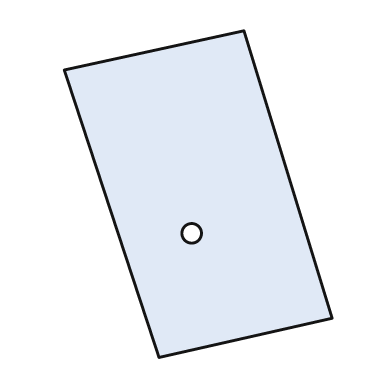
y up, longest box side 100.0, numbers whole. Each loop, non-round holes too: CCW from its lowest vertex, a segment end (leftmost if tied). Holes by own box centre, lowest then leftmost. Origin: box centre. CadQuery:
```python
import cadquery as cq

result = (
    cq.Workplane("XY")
    .moveTo(-12.0, -50.0)
    .lineTo(41.0, -38.0)
    .lineTo(14.0, 50.0)
    .lineTo(-41.0, 38.0)
    .close()
    .moveTo(-2.0, -12.0)
    .circle(3.0)
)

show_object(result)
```